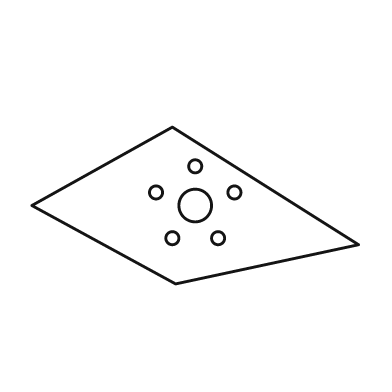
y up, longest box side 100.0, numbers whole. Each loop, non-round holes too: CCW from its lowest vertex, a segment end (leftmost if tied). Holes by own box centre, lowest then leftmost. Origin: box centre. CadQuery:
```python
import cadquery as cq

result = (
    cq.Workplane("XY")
    .moveTo(-6.0, -24.0)
    .lineTo(50.0, -12.0)
    .lineTo(-7.0, 24.0)
    .lineTo(-50.0, 0.0)
    .close()
    .moveTo(-7.0, -10.0)
    .circle(2.0)
    .moveTo(7.0, -10.0)
    .circle(2.0)
    .moveTo(0.0, 0.0)
    .circle(5.0)
    .moveTo(-12.0, 4.0)
    .circle(2.0)
    .moveTo(12.0, 4.0)
    .circle(2.0)
    .moveTo(0.0, 12.0)
    .circle(2.0)
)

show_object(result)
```